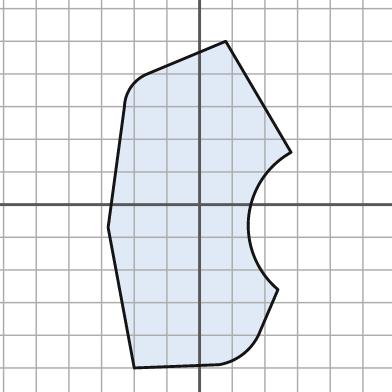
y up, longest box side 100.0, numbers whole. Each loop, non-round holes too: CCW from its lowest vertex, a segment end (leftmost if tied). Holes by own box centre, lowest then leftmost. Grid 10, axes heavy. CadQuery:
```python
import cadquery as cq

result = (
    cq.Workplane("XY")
    .moveTo(-20.0, -50.0)
    .lineTo(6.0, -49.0)
    .threePointArc((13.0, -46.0), (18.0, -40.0))
    .lineTo(24.0, -26.0)
    .threePointArc((15.0, -4.0), (28.0, 16.0))
    .lineTo(8.0, 50.0)
    .lineTo(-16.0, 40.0)
    .threePointArc((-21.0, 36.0), (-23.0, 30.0))
    .lineTo(-28.0, -7.0)
    .close()
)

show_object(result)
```